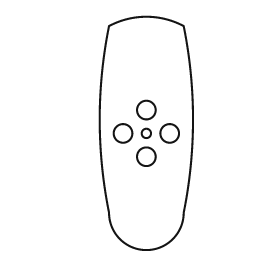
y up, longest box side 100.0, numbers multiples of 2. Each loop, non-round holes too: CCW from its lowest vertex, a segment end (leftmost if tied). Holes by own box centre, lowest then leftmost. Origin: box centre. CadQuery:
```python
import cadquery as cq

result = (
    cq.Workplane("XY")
    .moveTo(-16.0, -34.0)
    .threePointArc((0.0, -50.0), (16.0, -34.0))
    .threePointArc((20.0, 6.0), (16.0, 46.0))
    .threePointArc((0.0, 50.0), (-16.0, 46.0))
    .threePointArc((-20.0, 6.0), (-16.0, -34.0))
    .close()
    .moveTo(0.0, -10.0)
    .circle(4.0)
    .moveTo(-10.0, 0.0)
    .circle(4.0)
    .moveTo(0.0, 0.0)
    .circle(2.0)
    .moveTo(10.0, 0.0)
    .circle(4.0)
    .moveTo(0.0, 10.0)
    .circle(4.0)
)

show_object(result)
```